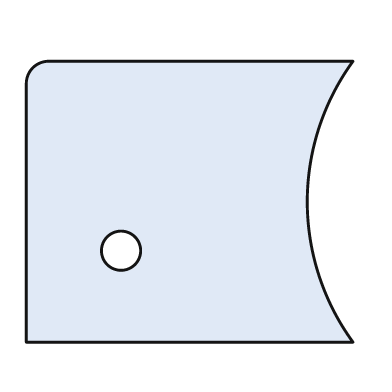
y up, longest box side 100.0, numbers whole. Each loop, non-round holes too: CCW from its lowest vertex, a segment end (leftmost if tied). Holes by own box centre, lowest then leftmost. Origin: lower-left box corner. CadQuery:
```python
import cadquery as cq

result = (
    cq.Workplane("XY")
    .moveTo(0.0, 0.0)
    .lineTo(100.0, 0.0)
    .threePointArc((86.0, 43.0), (100.0, 86.0))
    .lineTo(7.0, 86.0)
    .threePointArc((2.0, 84.0), (0.0, 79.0))
    .close()
    .moveTo(29.0, 28.0)
    .circle(6.0)
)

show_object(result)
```